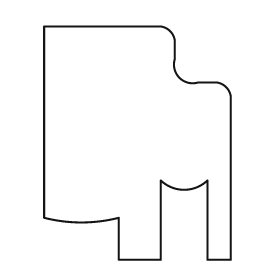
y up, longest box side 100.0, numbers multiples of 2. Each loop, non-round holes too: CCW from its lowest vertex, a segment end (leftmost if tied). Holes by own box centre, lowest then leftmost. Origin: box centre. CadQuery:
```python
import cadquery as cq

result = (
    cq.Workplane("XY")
    .moveTo(-8.0, -50.0)
    .lineTo(10.0, -50.0)
    .lineTo(10.0, -16.0)
    .threePointArc((20.0, -20.0), (30.0, -16.0))
    .lineTo(30.0, -50.0)
    .lineTo(40.0, -50.0)
    .lineTo(40.0, 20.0)
    .threePointArc((38.0, 24.0), (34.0, 26.0))
    .lineTo(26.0, 26.0)
    .threePointArc((18.0, 28.0), (16.0, 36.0))
    .lineTo(16.0, 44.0)
    .threePointArc((14.0, 48.0), (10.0, 50.0))
    .lineTo(-40.0, 50.0)
    .lineTo(-40.0, -32.0)
    .threePointArc((-24.0, -34.0), (-8.0, -32.0))
    .close()
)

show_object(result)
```